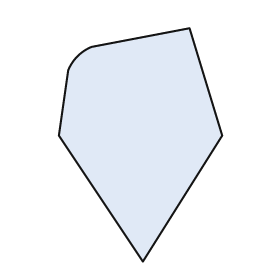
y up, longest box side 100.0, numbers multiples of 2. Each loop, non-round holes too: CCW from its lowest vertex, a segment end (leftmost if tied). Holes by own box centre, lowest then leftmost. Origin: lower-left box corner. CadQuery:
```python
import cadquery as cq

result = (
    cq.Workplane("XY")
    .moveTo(36.0, 0.0)
    .lineTo(70.0, 54.0)
    .lineTo(56.0, 100.0)
    .lineTo(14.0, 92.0)
    .threePointArc((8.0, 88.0), (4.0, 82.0))
    .lineTo(0.0, 54.0)
    .close()
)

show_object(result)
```